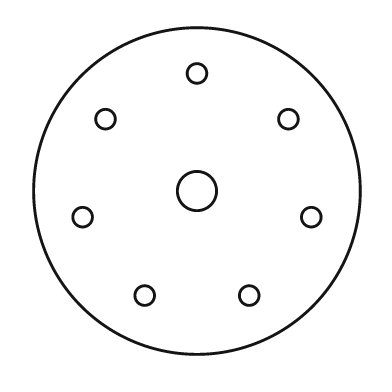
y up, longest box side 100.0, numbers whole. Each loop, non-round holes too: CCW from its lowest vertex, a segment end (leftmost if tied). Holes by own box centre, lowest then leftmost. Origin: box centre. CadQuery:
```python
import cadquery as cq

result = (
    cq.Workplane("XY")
    .moveTo(0.0, 0.0)
    .circle(50.0)
    .moveTo(-16.0, -32.0)
    .circle(3.0)
    .moveTo(16.0, -32.0)
    .circle(3.0)
    .moveTo(-35.0, -8.0)
    .circle(3.0)
    .moveTo(35.0, -8.0)
    .circle(3.0)
    .moveTo(0.0, 0.0)
    .circle(6.0)
    .moveTo(-28.0, 22.0)
    .circle(3.0)
    .moveTo(28.0, 22.0)
    .circle(3.0)
    .moveTo(0.0, 36.0)
    .circle(3.0)
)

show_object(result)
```